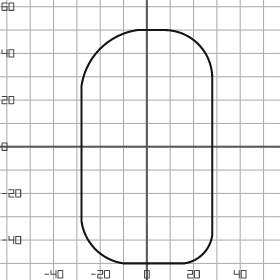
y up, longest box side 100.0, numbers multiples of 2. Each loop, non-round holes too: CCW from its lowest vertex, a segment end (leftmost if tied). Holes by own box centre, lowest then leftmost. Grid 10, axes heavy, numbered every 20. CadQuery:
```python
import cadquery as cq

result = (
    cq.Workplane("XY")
    .moveTo(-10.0, -50.0)
    .lineTo(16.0, -50.0)
    .threePointArc((24.0, -46.0), (28.0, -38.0))
    .lineTo(28.0, 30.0)
    .threePointArc((22.0, 44.0), (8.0, 50.0))
    .lineTo(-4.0, 50.0)
    .threePointArc((-20.0, 42.0), (-28.0, 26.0))
    .lineTo(-28.0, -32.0)
    .threePointArc((-22.0, -44.0), (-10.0, -50.0))
    .close()
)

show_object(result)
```